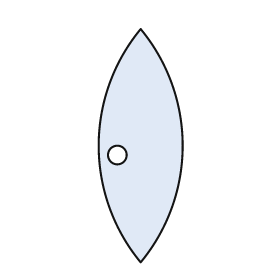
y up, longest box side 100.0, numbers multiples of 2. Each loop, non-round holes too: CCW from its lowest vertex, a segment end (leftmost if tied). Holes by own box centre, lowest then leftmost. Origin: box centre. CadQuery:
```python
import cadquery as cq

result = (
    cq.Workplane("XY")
    .moveTo(0.0, -50.0)
    .threePointArc((18.0, 0.0), (0.0, 50.0))
    .threePointArc((-18.0, 0.0), (0.0, -50.0))
    .close()
    .moveTo(-10.0, -4.0)
    .circle(4.0)
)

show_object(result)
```